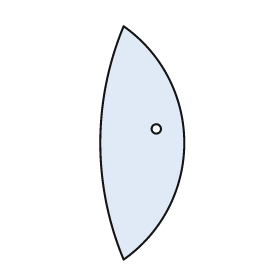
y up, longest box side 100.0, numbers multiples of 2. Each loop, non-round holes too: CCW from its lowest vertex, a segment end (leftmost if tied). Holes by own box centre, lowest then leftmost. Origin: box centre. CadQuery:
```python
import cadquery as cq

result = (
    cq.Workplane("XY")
    .moveTo(-8.0, -50.0)
    .threePointArc((18.0, 0.0), (-8.0, 50.0))
    .threePointArc((-18.0, 0.0), (-8.0, -50.0))
    .close()
    .moveTo(6.0, 6.0)
    .circle(2.0)
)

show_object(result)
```